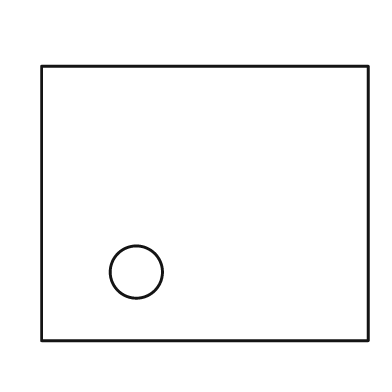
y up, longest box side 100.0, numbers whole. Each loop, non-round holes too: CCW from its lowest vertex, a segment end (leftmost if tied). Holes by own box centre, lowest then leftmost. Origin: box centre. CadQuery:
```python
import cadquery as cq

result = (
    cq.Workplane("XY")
    .moveTo(-50.0, -42.0)
    .lineTo(50.0, -42.0)
    .lineTo(50.0, 42.0)
    .lineTo(-50.0, 42.0)
    .close()
    .moveTo(-21.0, -21.0)
    .circle(8.0)
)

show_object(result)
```